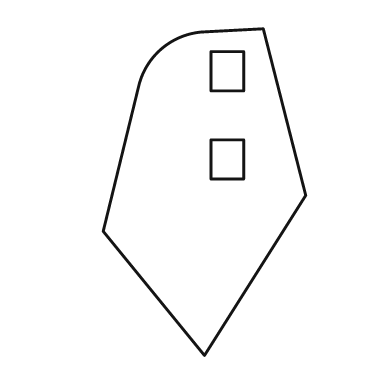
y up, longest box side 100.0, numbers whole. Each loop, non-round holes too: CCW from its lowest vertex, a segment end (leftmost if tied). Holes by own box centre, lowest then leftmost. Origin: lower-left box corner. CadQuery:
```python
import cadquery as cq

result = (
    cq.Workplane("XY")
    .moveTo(31.0, 0.0)
    .lineTo(62.0, 49.0)
    .lineTo(49.0, 100.0)
    .lineTo(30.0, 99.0)
    .threePointArc((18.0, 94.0), (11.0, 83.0))
    .lineTo(0.0, 38.0)
    .close()
    .moveTo(33.0, 54.0)
    .lineTo(43.0, 54.0)
    .lineTo(43.0, 66.0)
    .lineTo(33.0, 66.0)
    .close()
    .moveTo(33.0, 81.0)
    .lineTo(43.0, 81.0)
    .lineTo(43.0, 93.0)
    .lineTo(33.0, 93.0)
    .close()
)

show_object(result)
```